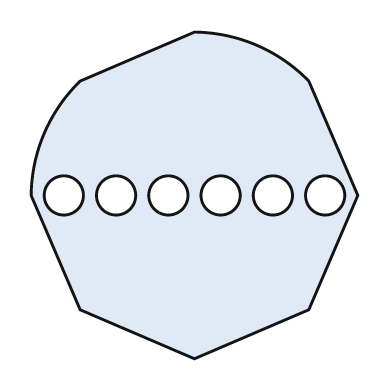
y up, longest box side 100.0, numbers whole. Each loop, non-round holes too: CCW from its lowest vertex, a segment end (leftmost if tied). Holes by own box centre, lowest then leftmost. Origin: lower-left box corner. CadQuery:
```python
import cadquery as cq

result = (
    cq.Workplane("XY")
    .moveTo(50.0, 0.0)
    .lineTo(85.0, 15.0)
    .lineTo(100.0, 50.0)
    .lineTo(85.0, 85.0)
    .threePointArc((69.0, 96.0), (50.0, 100.0))
    .lineTo(15.0, 85.0)
    .threePointArc((4.0, 69.0), (0.0, 50.0))
    .lineTo(15.0, 15.0)
    .close()
    .moveTo(10.0, 50.0)
    .circle(6.0)
    .moveTo(26.0, 50.0)
    .circle(6.0)
    .moveTo(42.0, 50.0)
    .circle(6.0)
    .moveTo(58.0, 50.0)
    .circle(6.0)
    .moveTo(74.0, 50.0)
    .circle(6.0)
    .moveTo(90.0, 50.0)
    .circle(6.0)
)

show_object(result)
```